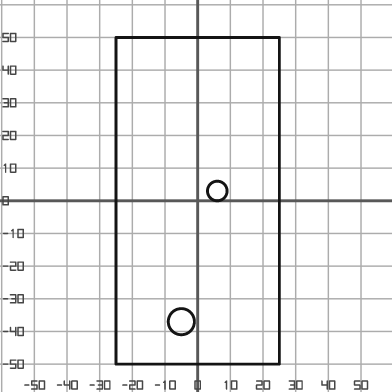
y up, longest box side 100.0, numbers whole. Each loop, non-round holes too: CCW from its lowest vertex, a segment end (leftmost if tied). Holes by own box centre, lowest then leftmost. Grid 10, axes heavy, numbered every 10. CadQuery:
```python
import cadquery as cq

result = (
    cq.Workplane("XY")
    .moveTo(-25.0, -50.0)
    .lineTo(25.0, -50.0)
    .lineTo(25.0, 50.0)
    .lineTo(-25.0, 50.0)
    .close()
    .moveTo(-5.0, -37.0)
    .circle(4.0)
    .moveTo(6.0, 3.0)
    .circle(3.0)
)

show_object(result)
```